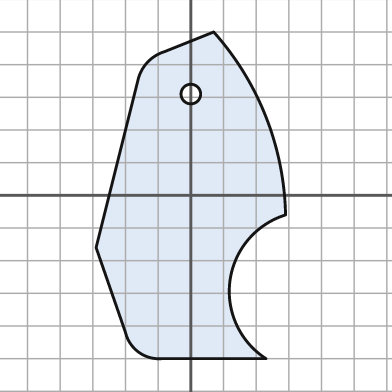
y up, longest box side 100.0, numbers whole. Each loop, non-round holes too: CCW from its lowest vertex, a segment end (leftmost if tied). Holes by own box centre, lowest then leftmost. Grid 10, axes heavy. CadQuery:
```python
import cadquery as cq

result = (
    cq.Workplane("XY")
    .moveTo(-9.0, -50.0)
    .lineTo(23.0, -50.0)
    .threePointArc((12.0, -26.0), (29.0, -6.0))
    .threePointArc((23.0, 24.0), (7.0, 50.0))
    .lineTo(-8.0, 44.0)
    .threePointArc((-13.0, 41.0), (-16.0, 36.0))
    .lineTo(-29.0, -16.0)
    .lineTo(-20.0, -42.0)
    .threePointArc((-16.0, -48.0), (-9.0, -50.0))
    .close()
    .moveTo(0.0, 31.0)
    .circle(3.0)
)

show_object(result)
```